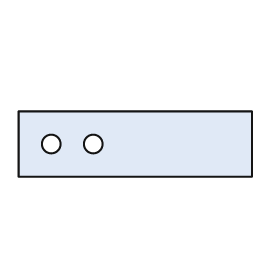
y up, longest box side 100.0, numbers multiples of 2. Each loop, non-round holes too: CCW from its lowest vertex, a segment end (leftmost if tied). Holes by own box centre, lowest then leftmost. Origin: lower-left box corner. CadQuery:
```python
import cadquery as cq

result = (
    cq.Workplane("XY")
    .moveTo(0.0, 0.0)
    .lineTo(100.0, 0.0)
    .lineTo(100.0, 28.0)
    .lineTo(0.0, 28.0)
    .close()
    .moveTo(14.0, 14.0)
    .circle(4.0)
    .moveTo(32.0, 14.0)
    .circle(4.0)
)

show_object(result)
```